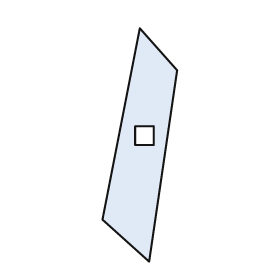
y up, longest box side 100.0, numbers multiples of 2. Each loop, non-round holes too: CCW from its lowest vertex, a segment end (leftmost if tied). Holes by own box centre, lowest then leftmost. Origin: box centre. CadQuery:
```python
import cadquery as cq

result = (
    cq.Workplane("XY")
    .moveTo(4.0, -50.0)
    .lineTo(16.0, 32.0)
    .lineTo(0.0, 50.0)
    .lineTo(-16.0, -32.0)
    .close()
    .moveTo(-2.0, 0.0)
    .lineTo(6.0, 0.0)
    .lineTo(6.0, 8.0)
    .lineTo(-2.0, 8.0)
    .close()
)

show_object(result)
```